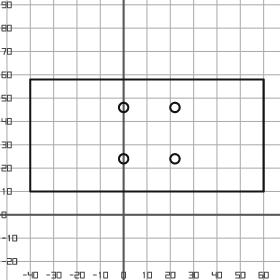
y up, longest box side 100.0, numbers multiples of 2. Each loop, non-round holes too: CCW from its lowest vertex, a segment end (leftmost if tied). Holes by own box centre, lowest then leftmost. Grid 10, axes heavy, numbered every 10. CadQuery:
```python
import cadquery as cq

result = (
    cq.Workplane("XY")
    .moveTo(-40.0, 10.0)
    .lineTo(60.0, 10.0)
    .lineTo(60.0, 58.0)
    .lineTo(-40.0, 58.0)
    .close()
    .moveTo(0.0, 24.0)
    .circle(2.0)
    .moveTo(22.0, 24.0)
    .circle(2.0)
    .moveTo(0.0, 46.0)
    .circle(2.0)
    .moveTo(22.0, 46.0)
    .circle(2.0)
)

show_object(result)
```